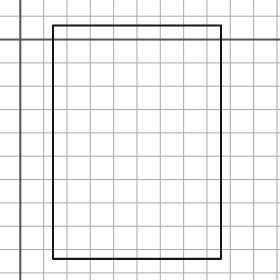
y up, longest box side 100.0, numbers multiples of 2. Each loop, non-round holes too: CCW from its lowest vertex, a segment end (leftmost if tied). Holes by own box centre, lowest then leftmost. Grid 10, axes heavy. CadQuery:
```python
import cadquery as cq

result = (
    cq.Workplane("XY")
    .moveTo(14.0, -94.0)
    .lineTo(86.0, -94.0)
    .lineTo(86.0, 6.0)
    .lineTo(14.0, 6.0)
    .close()
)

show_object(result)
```